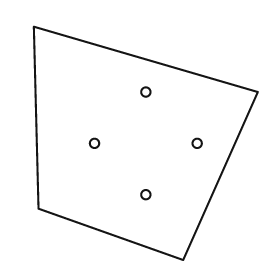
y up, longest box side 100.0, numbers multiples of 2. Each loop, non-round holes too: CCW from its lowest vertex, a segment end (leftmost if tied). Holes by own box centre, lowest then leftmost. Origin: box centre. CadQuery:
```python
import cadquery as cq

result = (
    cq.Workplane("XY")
    .moveTo(16.0, -50.0)
    .lineTo(48.0, 22.0)
    .lineTo(-48.0, 50.0)
    .lineTo(-46.0, -28.0)
    .close()
    .moveTo(0.0, -22.0)
    .circle(2.0)
    .moveTo(-22.0, 0.0)
    .circle(2.0)
    .moveTo(22.0, 0.0)
    .circle(2.0)
    .moveTo(0.0, 22.0)
    .circle(2.0)
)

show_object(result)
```